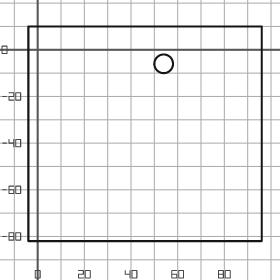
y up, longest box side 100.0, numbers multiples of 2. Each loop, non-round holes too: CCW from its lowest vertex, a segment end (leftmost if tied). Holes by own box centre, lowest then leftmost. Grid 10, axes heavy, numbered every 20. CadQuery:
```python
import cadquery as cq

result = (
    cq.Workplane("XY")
    .moveTo(-4.0, -82.0)
    .lineTo(96.0, -82.0)
    .lineTo(96.0, 10.0)
    .lineTo(-4.0, 10.0)
    .close()
    .moveTo(54.0, -6.0)
    .circle(4.0)
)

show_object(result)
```